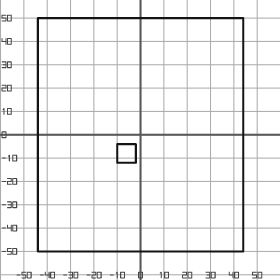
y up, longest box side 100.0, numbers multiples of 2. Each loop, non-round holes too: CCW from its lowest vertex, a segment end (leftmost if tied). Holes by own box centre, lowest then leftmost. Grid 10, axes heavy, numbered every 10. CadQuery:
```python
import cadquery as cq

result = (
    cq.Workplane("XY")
    .moveTo(-44.0, -50.0)
    .lineTo(44.0, -50.0)
    .lineTo(44.0, 50.0)
    .lineTo(-44.0, 50.0)
    .close()
    .moveTo(-10.0, -12.0)
    .lineTo(-2.0, -12.0)
    .lineTo(-2.0, -4.0)
    .lineTo(-10.0, -4.0)
    .close()
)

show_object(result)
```